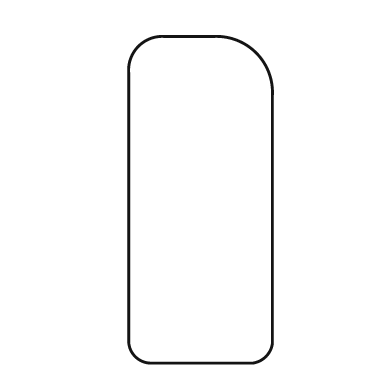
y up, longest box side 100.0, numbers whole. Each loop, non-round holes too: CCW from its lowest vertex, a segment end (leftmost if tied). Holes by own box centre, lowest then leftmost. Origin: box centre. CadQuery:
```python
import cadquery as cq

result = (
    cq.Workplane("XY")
    .moveTo(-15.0, -50.0)
    .lineTo(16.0, -50.0)
    .threePointArc((20.0, -48.0), (22.0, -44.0))
    .lineTo(22.0, 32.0)
    .threePointArc((17.0, 45.0), (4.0, 50.0))
    .lineTo(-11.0, 50.0)
    .threePointArc((-19.0, 47.0), (-22.0, 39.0))
    .lineTo(-22.0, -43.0)
    .threePointArc((-20.0, -48.0), (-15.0, -50.0))
    .close()
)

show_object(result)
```